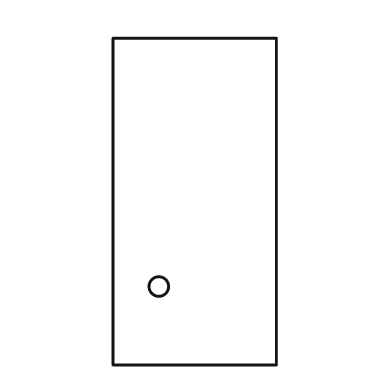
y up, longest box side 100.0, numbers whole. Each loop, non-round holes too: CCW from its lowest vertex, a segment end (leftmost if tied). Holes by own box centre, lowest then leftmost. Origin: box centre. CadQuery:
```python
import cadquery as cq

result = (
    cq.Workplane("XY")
    .moveTo(-25.0, -50.0)
    .lineTo(25.0, -50.0)
    .lineTo(25.0, 50.0)
    .lineTo(-25.0, 50.0)
    .close()
    .moveTo(-11.0, -26.0)
    .circle(3.0)
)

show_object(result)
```